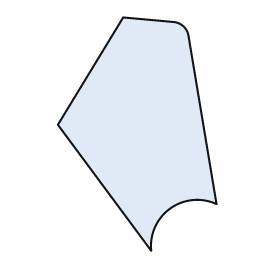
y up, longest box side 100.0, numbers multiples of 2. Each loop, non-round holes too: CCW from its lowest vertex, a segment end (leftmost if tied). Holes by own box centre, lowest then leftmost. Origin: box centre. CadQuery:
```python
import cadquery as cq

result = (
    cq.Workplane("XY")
    .moveTo(6.0, -50.0)
    .threePointArc((14.0, -32.0), (34.0, -30.0))
    .lineTo(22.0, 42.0)
    .threePointArc((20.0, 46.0), (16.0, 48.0))
    .lineTo(-6.0, 50.0)
    .lineTo(-34.0, 4.0)
    .close()
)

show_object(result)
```